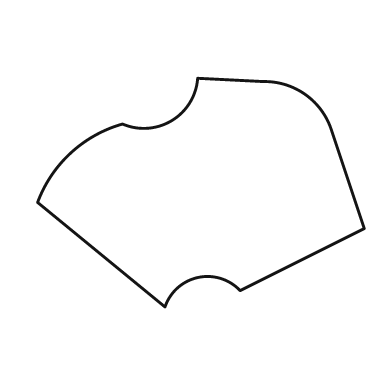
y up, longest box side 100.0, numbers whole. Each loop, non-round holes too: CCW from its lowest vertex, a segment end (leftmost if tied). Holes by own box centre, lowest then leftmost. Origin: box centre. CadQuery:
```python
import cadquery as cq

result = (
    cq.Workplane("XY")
    .moveTo(-11.0, -35.0)
    .threePointArc((-1.0, -26.0), (12.0, -30.0))
    .lineTo(50.0, -11.0)
    .lineTo(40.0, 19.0)
    .threePointArc((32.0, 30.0), (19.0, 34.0))
    .lineTo(-1.0, 35.0)
    .threePointArc((-9.0, 22.0), (-24.0, 21.0))
    .threePointArc((-40.0, 12.0), (-50.0, -3.0))
    .close()
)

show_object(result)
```